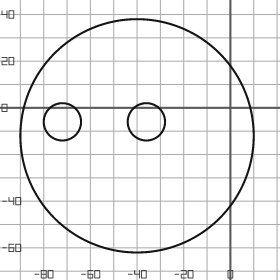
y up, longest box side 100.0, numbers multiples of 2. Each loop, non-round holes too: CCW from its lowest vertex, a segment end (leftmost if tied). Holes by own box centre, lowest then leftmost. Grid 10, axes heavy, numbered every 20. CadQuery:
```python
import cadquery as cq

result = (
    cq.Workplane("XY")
    .moveTo(-40.0, -12.0)
    .circle(50.0)
    .moveTo(-72.0, -6.0)
    .circle(8.0)
    .moveTo(-36.0, -6.0)
    .circle(8.0)
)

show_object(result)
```